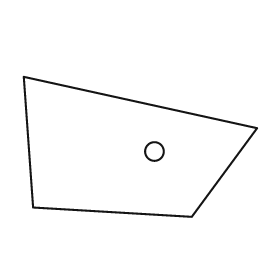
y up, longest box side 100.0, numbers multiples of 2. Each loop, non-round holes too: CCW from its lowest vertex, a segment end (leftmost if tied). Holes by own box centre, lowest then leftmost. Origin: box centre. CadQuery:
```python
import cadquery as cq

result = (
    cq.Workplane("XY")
    .moveTo(22.0, -30.0)
    .lineTo(50.0, 8.0)
    .lineTo(-50.0, 30.0)
    .lineTo(-46.0, -26.0)
    .close()
    .moveTo(6.0, -2.0)
    .circle(4.0)
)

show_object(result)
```